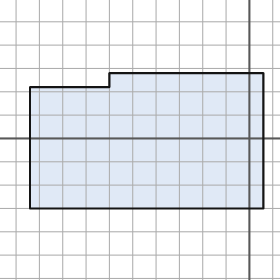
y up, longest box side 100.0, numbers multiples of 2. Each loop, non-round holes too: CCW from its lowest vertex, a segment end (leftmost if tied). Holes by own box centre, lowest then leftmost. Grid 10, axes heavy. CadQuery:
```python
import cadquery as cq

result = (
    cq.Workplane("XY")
    .moveTo(-94.0, -30.0)
    .lineTo(6.0, -30.0)
    .lineTo(6.0, 28.0)
    .lineTo(-60.0, 28.0)
    .lineTo(-60.0, 22.0)
    .lineTo(-94.0, 22.0)
    .close()
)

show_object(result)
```